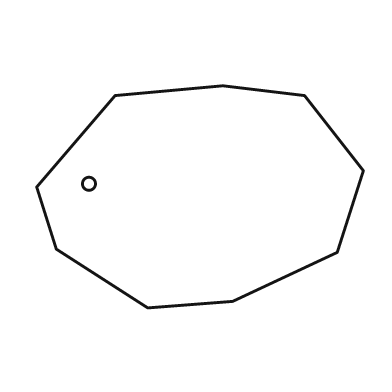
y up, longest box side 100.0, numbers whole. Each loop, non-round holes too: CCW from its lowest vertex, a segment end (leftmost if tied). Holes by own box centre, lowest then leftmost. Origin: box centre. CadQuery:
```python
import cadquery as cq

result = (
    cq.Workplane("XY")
    .moveTo(-16.0, -34.0)
    .lineTo(10.0, -32.0)
    .lineTo(42.0, -17.0)
    .lineTo(50.0, 8.0)
    .lineTo(32.0, 31.0)
    .lineTo(7.0, 34.0)
    .lineTo(-26.0, 31.0)
    .lineTo(-50.0, 3.0)
    .lineTo(-44.0, -16.0)
    .close()
    .moveTo(-34.0, 4.0)
    .circle(2.0)
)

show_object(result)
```